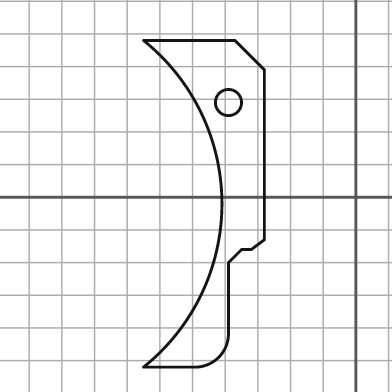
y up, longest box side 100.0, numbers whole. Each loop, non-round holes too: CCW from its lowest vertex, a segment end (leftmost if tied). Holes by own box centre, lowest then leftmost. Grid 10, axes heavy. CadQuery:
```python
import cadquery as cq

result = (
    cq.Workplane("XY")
    .moveTo(-65.0, -52.0)
    .lineTo(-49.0, -52.0)
    .threePointArc((-42.0, -49.0), (-39.0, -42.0))
    .lineTo(-39.0, -20.0)
    .lineTo(-35.0, -16.0)
    .lineTo(-32.0, -16.0)
    .lineTo(-28.0, -13.0)
    .lineTo(-28.0, 39.0)
    .lineTo(-37.0, 48.0)
    .lineTo(-65.0, 48.0)
    .threePointArc((-41.0, -2.0), (-65.0, -52.0))
    .close()
    .moveTo(-39.0, 29.0)
    .circle(4.0)
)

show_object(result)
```